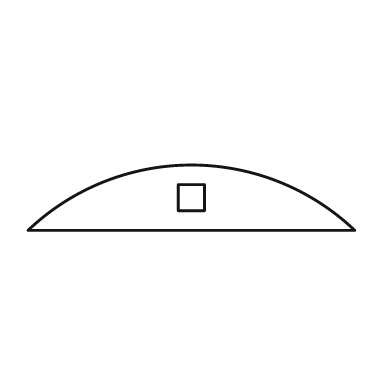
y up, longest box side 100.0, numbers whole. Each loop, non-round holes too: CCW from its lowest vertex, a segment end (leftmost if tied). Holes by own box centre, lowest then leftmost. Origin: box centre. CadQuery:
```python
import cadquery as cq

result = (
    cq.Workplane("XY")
    .moveTo(-50.0, -10.0)
    .lineTo(50.0, -10.0)
    .threePointArc((0.0, 10.0), (-50.0, -10.0))
    .close()
    .moveTo(-4.0, -4.0)
    .lineTo(4.0, -4.0)
    .lineTo(4.0, 4.0)
    .lineTo(-4.0, 4.0)
    .close()
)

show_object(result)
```